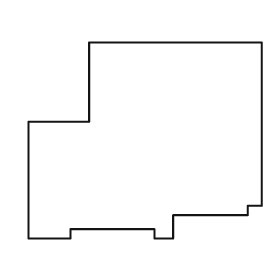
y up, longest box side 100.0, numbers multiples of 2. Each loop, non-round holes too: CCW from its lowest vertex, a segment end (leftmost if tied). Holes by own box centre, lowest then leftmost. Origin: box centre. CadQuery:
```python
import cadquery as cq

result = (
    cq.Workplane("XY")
    .moveTo(-50.0, -42.0)
    .lineTo(-32.0, -42.0)
    .lineTo(-32.0, -38.0)
    .lineTo(4.0, -38.0)
    .lineTo(4.0, -42.0)
    .lineTo(12.0, -42.0)
    .lineTo(12.0, -32.0)
    .lineTo(44.0, -32.0)
    .lineTo(44.0, -28.0)
    .lineTo(50.0, -28.0)
    .lineTo(50.0, 42.0)
    .lineTo(-24.0, 42.0)
    .lineTo(-24.0, 8.0)
    .lineTo(-50.0, 8.0)
    .close()
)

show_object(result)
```